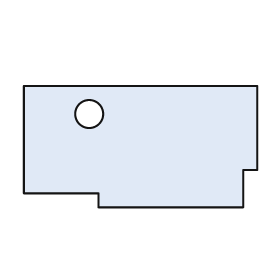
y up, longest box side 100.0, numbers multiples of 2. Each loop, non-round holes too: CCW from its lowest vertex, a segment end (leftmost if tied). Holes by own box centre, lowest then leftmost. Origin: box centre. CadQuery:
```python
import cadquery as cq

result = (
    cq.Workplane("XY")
    .moveTo(-18.0, -26.0)
    .lineTo(44.0, -26.0)
    .lineTo(44.0, -10.0)
    .lineTo(50.0, -10.0)
    .lineTo(50.0, 26.0)
    .lineTo(-50.0, 26.0)
    .lineTo(-50.0, -20.0)
    .lineTo(-18.0, -20.0)
    .close()
    .moveTo(-22.0, 14.0)
    .circle(6.0)
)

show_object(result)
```